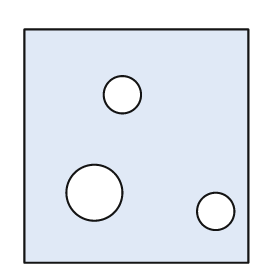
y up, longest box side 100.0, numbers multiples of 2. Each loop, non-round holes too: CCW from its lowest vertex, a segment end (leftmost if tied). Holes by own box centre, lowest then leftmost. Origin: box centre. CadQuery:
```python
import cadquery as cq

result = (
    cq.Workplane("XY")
    .moveTo(-48.0, -50.0)
    .lineTo(48.0, -50.0)
    .lineTo(48.0, 50.0)
    .lineTo(-48.0, 50.0)
    .close()
    .moveTo(34.0, -28.0)
    .circle(8.0)
    .moveTo(-18.0, -20.0)
    .circle(12.0)
    .moveTo(-6.0, 22.0)
    .circle(8.0)
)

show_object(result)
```